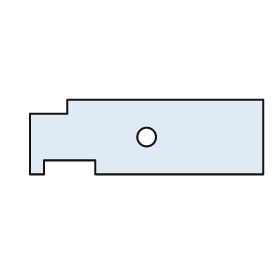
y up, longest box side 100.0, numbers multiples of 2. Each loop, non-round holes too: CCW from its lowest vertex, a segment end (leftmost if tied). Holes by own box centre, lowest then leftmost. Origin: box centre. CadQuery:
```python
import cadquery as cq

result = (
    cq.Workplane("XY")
    .moveTo(-50.0, -16.0)
    .lineTo(-44.0, -16.0)
    .lineTo(-44.0, -10.0)
    .lineTo(-22.0, -10.0)
    .lineTo(-22.0, -16.0)
    .lineTo(50.0, -16.0)
    .lineTo(50.0, 16.0)
    .lineTo(-34.0, 16.0)
    .lineTo(-34.0, 10.0)
    .lineTo(-50.0, 10.0)
    .close()
    .moveTo(0.0, 0.0)
    .circle(4.0)
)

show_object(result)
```